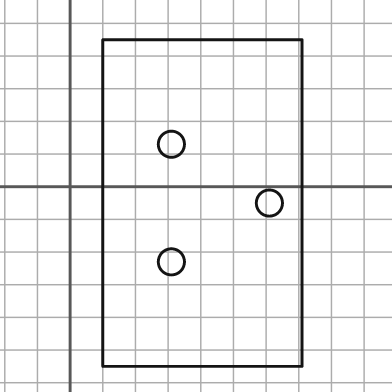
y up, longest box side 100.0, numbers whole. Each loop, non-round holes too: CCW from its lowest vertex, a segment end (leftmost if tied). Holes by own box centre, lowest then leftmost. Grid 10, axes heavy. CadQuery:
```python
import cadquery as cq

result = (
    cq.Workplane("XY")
    .moveTo(10.0, -55.0)
    .lineTo(71.0, -55.0)
    .lineTo(71.0, 45.0)
    .lineTo(10.0, 45.0)
    .close()
    .moveTo(31.0, -23.0)
    .circle(4.0)
    .moveTo(61.0, -5.0)
    .circle(4.0)
    .moveTo(31.0, 13.0)
    .circle(4.0)
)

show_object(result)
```